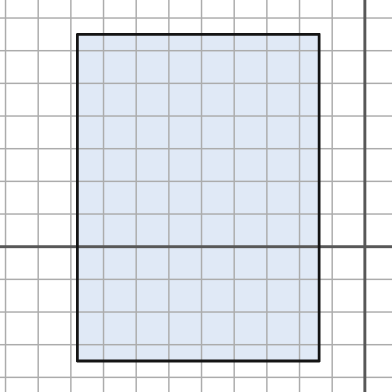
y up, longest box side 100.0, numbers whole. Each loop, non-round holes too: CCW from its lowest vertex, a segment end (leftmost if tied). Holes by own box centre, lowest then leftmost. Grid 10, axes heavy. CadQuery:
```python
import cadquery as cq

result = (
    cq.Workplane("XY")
    .moveTo(-88.0, -35.0)
    .lineTo(-14.0, -35.0)
    .lineTo(-14.0, 65.0)
    .lineTo(-88.0, 65.0)
    .close()
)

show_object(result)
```